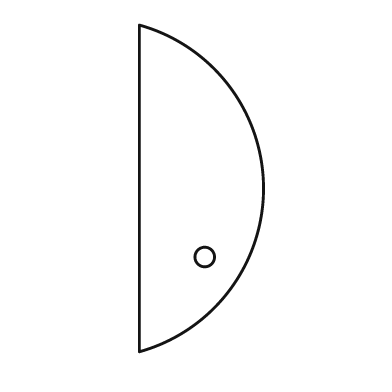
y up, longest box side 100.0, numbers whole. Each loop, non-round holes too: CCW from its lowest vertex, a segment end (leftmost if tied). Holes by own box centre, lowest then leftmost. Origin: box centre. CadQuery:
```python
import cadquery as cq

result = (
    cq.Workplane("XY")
    .moveTo(-19.0, -50.0)
    .threePointArc((19.0, 0.0), (-19.0, 50.0))
    .close()
    .moveTo(1.0, -21.0)
    .circle(3.0)
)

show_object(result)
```